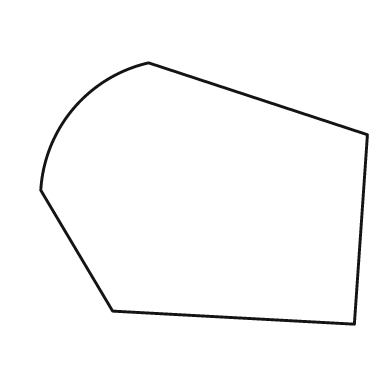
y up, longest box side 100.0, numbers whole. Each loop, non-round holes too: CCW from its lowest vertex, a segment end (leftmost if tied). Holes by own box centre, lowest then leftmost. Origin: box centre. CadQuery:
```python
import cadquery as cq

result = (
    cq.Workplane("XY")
    .moveTo(46.0, -40.0)
    .lineTo(50.0, 18.0)
    .lineTo(-17.0, 40.0)
    .threePointArc((-40.0, 26.0), (-50.0, 1.0))
    .lineTo(-28.0, -36.0)
    .close()
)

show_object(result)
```